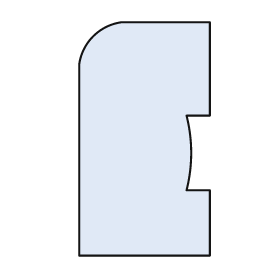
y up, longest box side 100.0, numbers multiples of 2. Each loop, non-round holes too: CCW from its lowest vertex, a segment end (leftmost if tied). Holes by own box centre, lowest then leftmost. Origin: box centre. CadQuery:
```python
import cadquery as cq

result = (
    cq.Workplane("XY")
    .moveTo(-28.0, -50.0)
    .lineTo(28.0, -50.0)
    .lineTo(28.0, -22.0)
    .lineTo(18.0, -22.0)
    .threePointArc((20.0, -6.0), (18.0, 10.0))
    .lineTo(28.0, 10.0)
    .lineTo(28.0, 50.0)
    .lineTo(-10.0, 50.0)
    .threePointArc((-22.0, 44.0), (-28.0, 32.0))
    .close()
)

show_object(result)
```